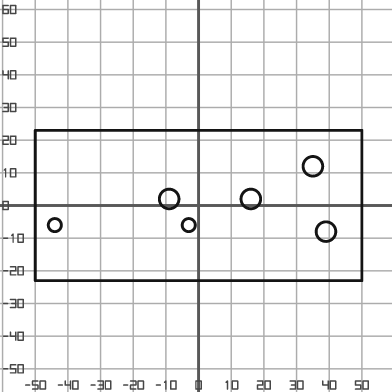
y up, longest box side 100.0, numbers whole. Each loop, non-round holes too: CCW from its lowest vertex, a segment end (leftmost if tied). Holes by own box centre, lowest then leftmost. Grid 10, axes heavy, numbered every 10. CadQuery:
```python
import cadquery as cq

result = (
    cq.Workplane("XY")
    .moveTo(-50.0, -23.0)
    .lineTo(50.0, -23.0)
    .lineTo(50.0, 23.0)
    .lineTo(-50.0, 23.0)
    .close()
    .moveTo(39.0, -8.0)
    .circle(3.0)
    .moveTo(-44.0, -6.0)
    .circle(2.0)
    .moveTo(-3.0, -6.0)
    .circle(2.0)
    .moveTo(-9.0, 2.0)
    .circle(3.0)
    .moveTo(16.0, 2.0)
    .circle(3.0)
    .moveTo(35.0, 12.0)
    .circle(3.0)
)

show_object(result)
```